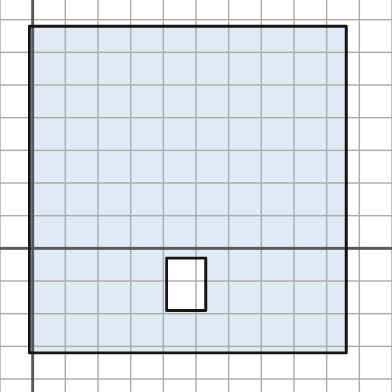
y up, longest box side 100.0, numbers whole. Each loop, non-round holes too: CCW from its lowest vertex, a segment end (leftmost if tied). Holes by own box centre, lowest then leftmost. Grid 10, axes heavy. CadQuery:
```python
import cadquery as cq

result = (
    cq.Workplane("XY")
    .moveTo(-1.0, -32.0)
    .lineTo(96.0, -32.0)
    .lineTo(96.0, 68.0)
    .lineTo(-1.0, 68.0)
    .close()
    .moveTo(41.0, -19.0)
    .lineTo(53.0, -19.0)
    .lineTo(53.0, -3.0)
    .lineTo(41.0, -3.0)
    .close()
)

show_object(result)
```